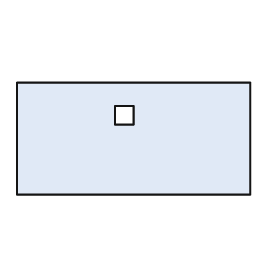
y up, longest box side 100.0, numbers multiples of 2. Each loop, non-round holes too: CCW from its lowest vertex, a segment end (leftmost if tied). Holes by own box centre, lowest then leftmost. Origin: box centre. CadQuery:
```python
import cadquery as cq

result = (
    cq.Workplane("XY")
    .moveTo(-50.0, -24.0)
    .lineTo(50.0, -24.0)
    .lineTo(50.0, 24.0)
    .lineTo(-50.0, 24.0)
    .close()
    .moveTo(-8.0, 6.0)
    .lineTo(0.0, 6.0)
    .lineTo(0.0, 14.0)
    .lineTo(-8.0, 14.0)
    .close()
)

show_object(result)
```